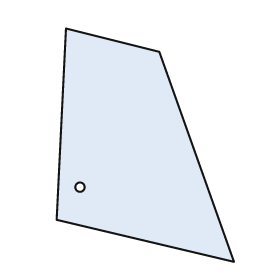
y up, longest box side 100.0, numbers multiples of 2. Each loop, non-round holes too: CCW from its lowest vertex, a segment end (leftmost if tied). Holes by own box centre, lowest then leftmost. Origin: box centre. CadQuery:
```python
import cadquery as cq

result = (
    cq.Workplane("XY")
    .moveTo(38.0, -50.0)
    .lineTo(6.0, 40.0)
    .lineTo(-34.0, 50.0)
    .lineTo(-38.0, -32.0)
    .close()
    .moveTo(-28.0, -18.0)
    .circle(2.0)
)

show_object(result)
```